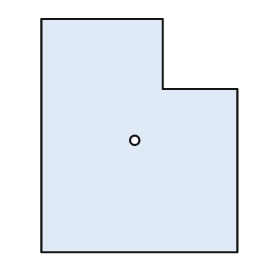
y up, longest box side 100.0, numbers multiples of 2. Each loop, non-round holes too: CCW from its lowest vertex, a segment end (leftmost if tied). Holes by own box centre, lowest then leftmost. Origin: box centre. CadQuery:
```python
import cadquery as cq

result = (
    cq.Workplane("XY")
    .moveTo(-42.0, -50.0)
    .lineTo(42.0, -50.0)
    .lineTo(42.0, 20.0)
    .lineTo(10.0, 20.0)
    .lineTo(10.0, 50.0)
    .lineTo(-42.0, 50.0)
    .close()
    .moveTo(-2.0, -2.0)
    .circle(2.0)
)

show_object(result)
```